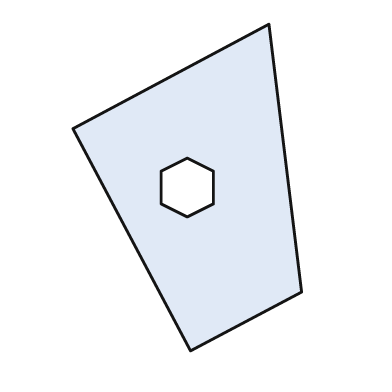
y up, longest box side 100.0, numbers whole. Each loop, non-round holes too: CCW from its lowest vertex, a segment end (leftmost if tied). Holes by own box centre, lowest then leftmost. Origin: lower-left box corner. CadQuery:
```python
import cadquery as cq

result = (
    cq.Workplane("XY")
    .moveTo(36.0, 0.0)
    .lineTo(70.0, 18.0)
    .lineTo(60.0, 100.0)
    .lineTo(0.0, 68.0)
    .close()
    .moveTo(35.0, 41.0)
    .lineTo(43.0, 45.0)
    .lineTo(43.0, 55.0)
    .lineTo(35.0, 59.0)
    .lineTo(27.0, 55.0)
    .lineTo(27.0, 45.0)
    .close()
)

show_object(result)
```